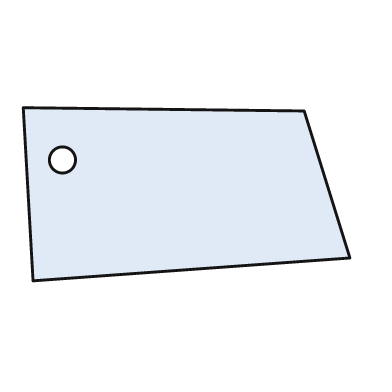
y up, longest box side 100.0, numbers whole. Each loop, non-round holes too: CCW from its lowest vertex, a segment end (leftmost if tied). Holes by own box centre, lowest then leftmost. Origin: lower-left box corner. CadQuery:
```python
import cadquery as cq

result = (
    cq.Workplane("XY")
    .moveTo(3.0, 0.0)
    .lineTo(100.0, 7.0)
    .lineTo(86.0, 52.0)
    .lineTo(0.0, 53.0)
    .close()
    .moveTo(12.0, 37.0)
    .circle(4.0)
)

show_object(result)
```